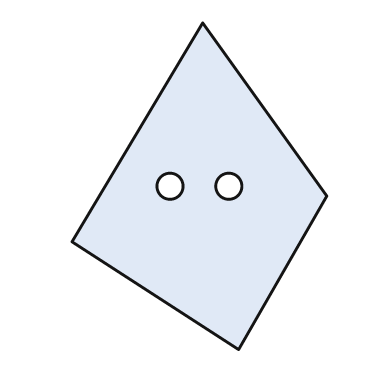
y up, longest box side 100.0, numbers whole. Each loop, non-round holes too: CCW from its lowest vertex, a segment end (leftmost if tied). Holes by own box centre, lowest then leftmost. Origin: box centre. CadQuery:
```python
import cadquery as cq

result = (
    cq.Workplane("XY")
    .moveTo(12.0, -50.0)
    .lineTo(39.0, -3.0)
    .lineTo(1.0, 50.0)
    .lineTo(-39.0, -17.0)
    .close()
    .moveTo(-9.0, 0.0)
    .circle(4.0)
    .moveTo(9.0, 0.0)
    .circle(4.0)
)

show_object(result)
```